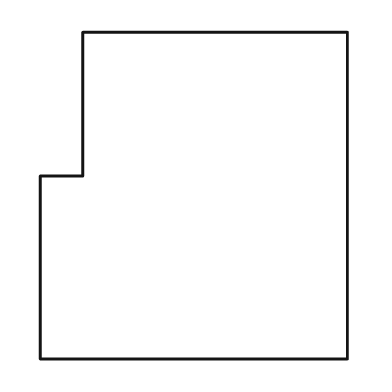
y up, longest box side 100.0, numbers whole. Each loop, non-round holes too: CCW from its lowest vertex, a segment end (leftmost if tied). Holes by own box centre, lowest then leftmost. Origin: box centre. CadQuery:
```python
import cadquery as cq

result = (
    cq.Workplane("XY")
    .moveTo(-47.0, -50.0)
    .lineTo(47.0, -50.0)
    .lineTo(47.0, 50.0)
    .lineTo(-34.0, 50.0)
    .lineTo(-34.0, 6.0)
    .lineTo(-47.0, 6.0)
    .close()
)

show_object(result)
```